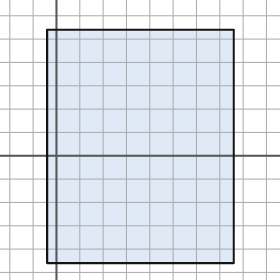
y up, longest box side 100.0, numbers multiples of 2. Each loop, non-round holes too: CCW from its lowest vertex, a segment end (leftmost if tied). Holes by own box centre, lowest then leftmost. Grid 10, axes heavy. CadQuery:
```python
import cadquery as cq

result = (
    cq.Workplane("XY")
    .moveTo(-4.0, -46.0)
    .lineTo(76.0, -46.0)
    .lineTo(76.0, 54.0)
    .lineTo(-4.0, 54.0)
    .close()
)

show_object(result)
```